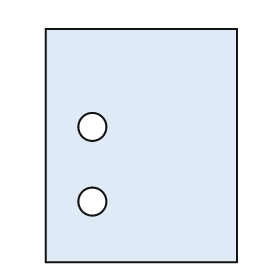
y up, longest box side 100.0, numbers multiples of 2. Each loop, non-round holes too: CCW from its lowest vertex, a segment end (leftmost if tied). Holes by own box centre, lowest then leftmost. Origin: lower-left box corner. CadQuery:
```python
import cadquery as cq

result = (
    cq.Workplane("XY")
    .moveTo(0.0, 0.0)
    .lineTo(82.0, 0.0)
    .lineTo(82.0, 100.0)
    .lineTo(0.0, 100.0)
    .close()
    .moveTo(20.0, 26.0)
    .circle(6.0)
    .moveTo(20.0, 58.0)
    .circle(6.0)
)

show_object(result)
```